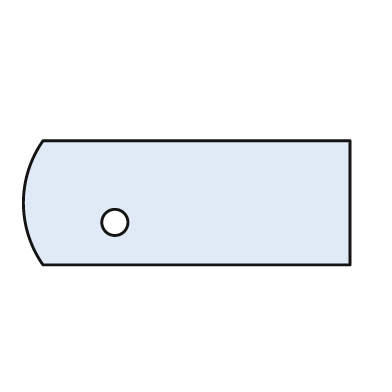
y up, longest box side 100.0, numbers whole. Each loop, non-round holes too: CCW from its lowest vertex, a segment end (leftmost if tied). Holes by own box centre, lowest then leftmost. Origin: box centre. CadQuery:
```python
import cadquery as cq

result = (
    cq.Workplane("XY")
    .moveTo(-44.0, -19.0)
    .lineTo(50.0, -19.0)
    .lineTo(50.0, 19.0)
    .lineTo(-44.0, 19.0)
    .threePointArc((-50.0, 0.0), (-44.0, -19.0))
    .close()
    .moveTo(-22.0, -6.0)
    .circle(4.0)
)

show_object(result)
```